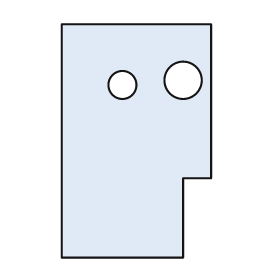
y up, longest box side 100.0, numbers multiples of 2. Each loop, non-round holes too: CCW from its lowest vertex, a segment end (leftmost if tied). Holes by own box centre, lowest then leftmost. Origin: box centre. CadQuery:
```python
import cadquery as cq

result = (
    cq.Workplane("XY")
    .moveTo(-32.0, -50.0)
    .lineTo(20.0, -50.0)
    .lineTo(20.0, -16.0)
    .lineTo(32.0, -16.0)
    .lineTo(32.0, 50.0)
    .lineTo(-32.0, 50.0)
    .close()
    .moveTo(-6.0, 24.0)
    .circle(6.0)
    .moveTo(20.0, 26.0)
    .circle(8.0)
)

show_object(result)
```